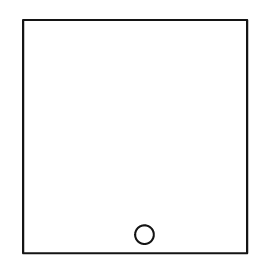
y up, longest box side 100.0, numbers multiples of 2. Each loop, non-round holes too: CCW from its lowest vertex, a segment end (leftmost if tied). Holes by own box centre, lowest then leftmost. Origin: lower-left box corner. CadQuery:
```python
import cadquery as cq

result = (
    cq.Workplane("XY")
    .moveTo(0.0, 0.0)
    .lineTo(96.0, 0.0)
    .lineTo(96.0, 100.0)
    .lineTo(0.0, 100.0)
    .close()
    .moveTo(52.0, 8.0)
    .circle(4.0)
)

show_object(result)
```